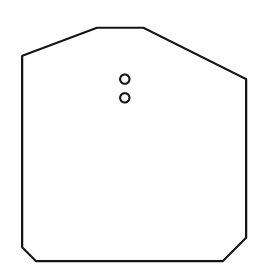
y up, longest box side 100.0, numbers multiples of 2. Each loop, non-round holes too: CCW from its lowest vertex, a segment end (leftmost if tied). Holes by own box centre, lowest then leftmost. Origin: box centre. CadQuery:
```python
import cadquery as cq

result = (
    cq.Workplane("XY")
    .moveTo(-42.0, -50.0)
    .lineTo(38.0, -50.0)
    .lineTo(48.0, -40.0)
    .lineTo(48.0, 28.0)
    .lineTo(4.0, 50.0)
    .lineTo(-16.0, 50.0)
    .lineTo(-48.0, 38.0)
    .lineTo(-48.0, -44.0)
    .close()
    .moveTo(-4.0, 20.0)
    .circle(2.0)
    .moveTo(-4.0, 28.0)
    .circle(2.0)
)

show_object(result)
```